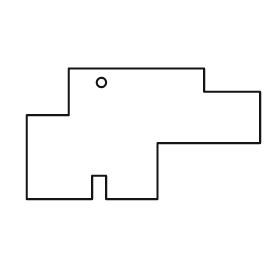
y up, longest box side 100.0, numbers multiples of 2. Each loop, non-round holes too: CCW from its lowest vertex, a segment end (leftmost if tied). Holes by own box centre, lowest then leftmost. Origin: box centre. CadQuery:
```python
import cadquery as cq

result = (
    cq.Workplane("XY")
    .moveTo(-50.0, -28.0)
    .lineTo(-22.0, -28.0)
    .lineTo(-22.0, -18.0)
    .lineTo(-16.0, -18.0)
    .lineTo(-16.0, -28.0)
    .lineTo(6.0, -28.0)
    .lineTo(6.0, -4.0)
    .lineTo(50.0, -4.0)
    .lineTo(50.0, 18.0)
    .lineTo(26.0, 18.0)
    .lineTo(26.0, 28.0)
    .lineTo(-32.0, 28.0)
    .lineTo(-32.0, 8.0)
    .lineTo(-50.0, 8.0)
    .close()
    .moveTo(-18.0, 22.0)
    .circle(2.0)
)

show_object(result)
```